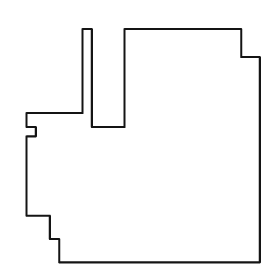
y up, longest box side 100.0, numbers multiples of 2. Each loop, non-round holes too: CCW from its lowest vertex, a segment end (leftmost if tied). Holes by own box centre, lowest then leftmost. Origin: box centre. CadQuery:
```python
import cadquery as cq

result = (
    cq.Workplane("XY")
    .moveTo(-36.0, -50.0)
    .lineTo(50.0, -50.0)
    .lineTo(50.0, 38.0)
    .lineTo(42.0, 38.0)
    .lineTo(42.0, 50.0)
    .lineTo(-8.0, 50.0)
    .lineTo(-8.0, 8.0)
    .lineTo(-22.0, 8.0)
    .lineTo(-22.0, 50.0)
    .lineTo(-26.0, 50.0)
    .lineTo(-26.0, 14.0)
    .lineTo(-50.0, 14.0)
    .lineTo(-50.0, 8.0)
    .lineTo(-46.0, 8.0)
    .lineTo(-46.0, 4.0)
    .lineTo(-50.0, 4.0)
    .lineTo(-50.0, -30.0)
    .lineTo(-40.0, -30.0)
    .lineTo(-40.0, -40.0)
    .lineTo(-36.0, -40.0)
    .close()
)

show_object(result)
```